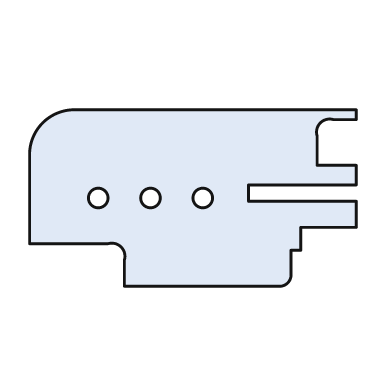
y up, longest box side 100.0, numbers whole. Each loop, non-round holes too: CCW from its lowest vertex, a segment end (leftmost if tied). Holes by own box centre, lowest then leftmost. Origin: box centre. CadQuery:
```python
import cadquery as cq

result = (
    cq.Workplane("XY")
    .moveTo(-21.0, -27.0)
    .lineTo(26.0, -27.0)
    .threePointArc((29.0, -26.0), (30.0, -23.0))
    .lineTo(30.0, -16.0)
    .lineTo(33.0, -16.0)
    .lineTo(33.0, -9.0)
    .lineTo(50.0, -9.0)
    .lineTo(50.0, -1.0)
    .lineTo(17.0, -1.0)
    .lineTo(17.0, 4.0)
    .lineTo(50.0, 4.0)
    .lineTo(50.0, 10.0)
    .lineTo(38.0, 10.0)
    .lineTo(38.0, 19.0)
    .threePointArc((39.0, 23.0), (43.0, 24.0))
    .lineTo(50.0, 24.0)
    .lineTo(50.0, 27.0)
    .lineTo(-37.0, 27.0)
    .threePointArc((-46.0, 23.0), (-50.0, 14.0))
    .lineTo(-50.0, -14.0)
    .lineTo(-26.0, -14.0)
    .threePointArc((-22.0, -15.0), (-21.0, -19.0))
    .close()
    .moveTo(-29.0, 0.0)
    .circle(3.0)
    .moveTo(-13.0, 0.0)
    .circle(3.0)
    .moveTo(3.0, 0.0)
    .circle(3.0)
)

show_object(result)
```